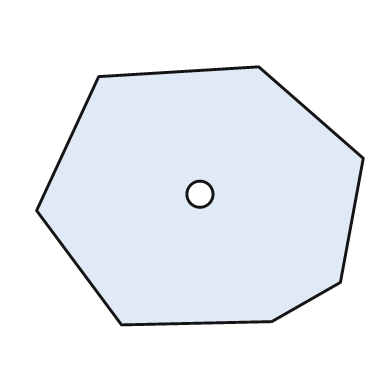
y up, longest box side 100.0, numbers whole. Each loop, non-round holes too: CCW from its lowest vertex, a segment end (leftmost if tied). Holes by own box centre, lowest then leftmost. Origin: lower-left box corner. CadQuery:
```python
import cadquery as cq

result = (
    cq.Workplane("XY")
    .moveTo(26.0, 0.0)
    .lineTo(72.0, 1.0)
    .lineTo(93.0, 13.0)
    .lineTo(100.0, 51.0)
    .lineTo(68.0, 79.0)
    .lineTo(19.0, 76.0)
    .lineTo(0.0, 35.0)
    .close()
    .moveTo(50.0, 40.0)
    .circle(4.0)
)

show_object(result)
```